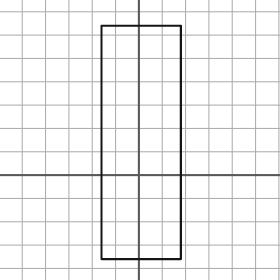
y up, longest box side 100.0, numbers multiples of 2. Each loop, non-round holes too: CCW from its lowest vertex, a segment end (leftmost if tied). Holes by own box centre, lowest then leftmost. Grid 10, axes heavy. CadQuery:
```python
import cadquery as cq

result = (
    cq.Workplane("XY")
    .moveTo(-16.0, -36.0)
    .lineTo(18.0, -36.0)
    .lineTo(18.0, 64.0)
    .lineTo(-16.0, 64.0)
    .close()
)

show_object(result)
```